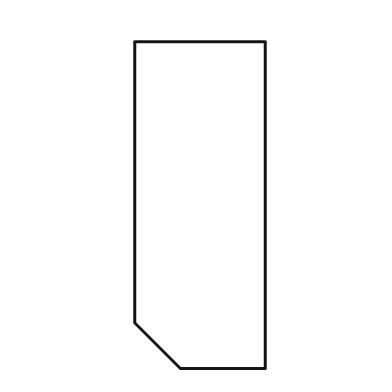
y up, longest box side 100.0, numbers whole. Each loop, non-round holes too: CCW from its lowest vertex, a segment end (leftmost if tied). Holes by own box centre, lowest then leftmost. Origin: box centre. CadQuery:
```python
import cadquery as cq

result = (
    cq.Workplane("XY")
    .moveTo(-6.0, -50.0)
    .lineTo(20.0, -50.0)
    .lineTo(20.0, 50.0)
    .lineTo(-20.0, 50.0)
    .lineTo(-20.0, -36.0)
    .close()
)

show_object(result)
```